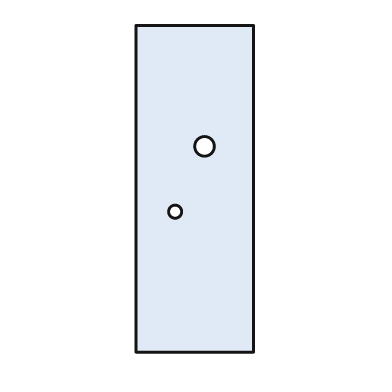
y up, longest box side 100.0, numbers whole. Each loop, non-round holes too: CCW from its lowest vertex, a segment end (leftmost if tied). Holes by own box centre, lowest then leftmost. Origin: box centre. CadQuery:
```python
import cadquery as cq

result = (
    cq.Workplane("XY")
    .moveTo(-18.0, -50.0)
    .lineTo(18.0, -50.0)
    .lineTo(18.0, 50.0)
    .lineTo(-18.0, 50.0)
    .close()
    .moveTo(-6.0, -7.0)
    .circle(2.0)
    .moveTo(3.0, 13.0)
    .circle(3.0)
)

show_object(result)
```